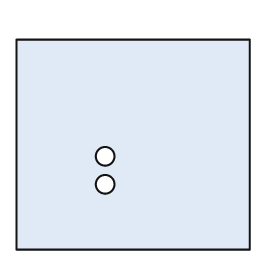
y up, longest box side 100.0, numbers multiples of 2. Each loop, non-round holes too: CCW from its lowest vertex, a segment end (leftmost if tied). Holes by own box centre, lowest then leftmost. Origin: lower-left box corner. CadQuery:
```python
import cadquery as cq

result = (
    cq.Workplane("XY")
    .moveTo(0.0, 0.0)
    .lineTo(100.0, 0.0)
    .lineTo(100.0, 90.0)
    .lineTo(0.0, 90.0)
    .close()
    .moveTo(38.0, 28.0)
    .circle(4.0)
    .moveTo(38.0, 40.0)
    .circle(4.0)
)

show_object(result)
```